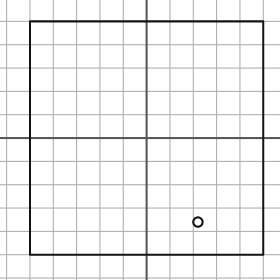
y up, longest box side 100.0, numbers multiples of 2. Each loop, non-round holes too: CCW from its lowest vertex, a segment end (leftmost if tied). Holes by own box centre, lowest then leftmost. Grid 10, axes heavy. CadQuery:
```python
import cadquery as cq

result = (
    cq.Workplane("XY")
    .moveTo(-50.0, -50.0)
    .lineTo(50.0, -50.0)
    .lineTo(50.0, 50.0)
    .lineTo(-50.0, 50.0)
    .close()
    .moveTo(22.0, -36.0)
    .circle(2.0)
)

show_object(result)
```